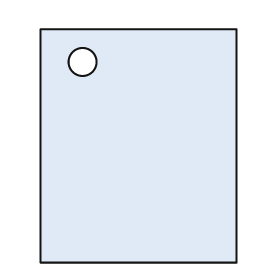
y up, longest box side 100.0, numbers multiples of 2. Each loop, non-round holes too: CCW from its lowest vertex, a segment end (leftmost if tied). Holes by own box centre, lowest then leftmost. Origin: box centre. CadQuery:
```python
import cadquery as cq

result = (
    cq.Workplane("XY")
    .moveTo(-42.0, -50.0)
    .lineTo(42.0, -50.0)
    .lineTo(42.0, 50.0)
    .lineTo(-42.0, 50.0)
    .close()
    .moveTo(-24.0, 36.0)
    .circle(6.0)
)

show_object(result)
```